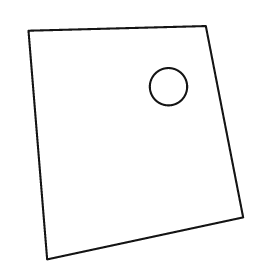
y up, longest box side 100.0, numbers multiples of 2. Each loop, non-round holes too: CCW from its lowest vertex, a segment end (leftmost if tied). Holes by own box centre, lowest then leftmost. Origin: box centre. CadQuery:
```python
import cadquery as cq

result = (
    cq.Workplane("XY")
    .moveTo(-38.0, -50.0)
    .lineTo(46.0, -32.0)
    .lineTo(30.0, 50.0)
    .lineTo(-46.0, 48.0)
    .close()
    .moveTo(14.0, 24.0)
    .circle(8.0)
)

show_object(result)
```